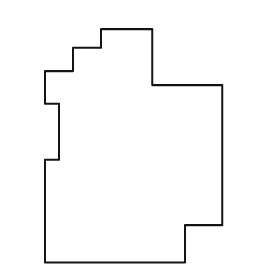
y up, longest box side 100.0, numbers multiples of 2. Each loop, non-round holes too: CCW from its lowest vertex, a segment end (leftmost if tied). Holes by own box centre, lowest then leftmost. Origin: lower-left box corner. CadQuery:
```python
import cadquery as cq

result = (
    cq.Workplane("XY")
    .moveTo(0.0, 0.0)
    .lineTo(60.0, 0.0)
    .lineTo(60.0, 16.0)
    .lineTo(76.0, 16.0)
    .lineTo(76.0, 76.0)
    .lineTo(46.0, 76.0)
    .lineTo(46.0, 100.0)
    .lineTo(24.0, 100.0)
    .lineTo(24.0, 92.0)
    .lineTo(12.0, 92.0)
    .lineTo(12.0, 82.0)
    .lineTo(0.0, 82.0)
    .lineTo(0.0, 68.0)
    .lineTo(6.0, 68.0)
    .lineTo(6.0, 44.0)
    .lineTo(0.0, 44.0)
    .close()
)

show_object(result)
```